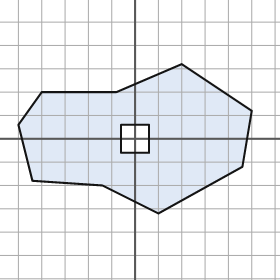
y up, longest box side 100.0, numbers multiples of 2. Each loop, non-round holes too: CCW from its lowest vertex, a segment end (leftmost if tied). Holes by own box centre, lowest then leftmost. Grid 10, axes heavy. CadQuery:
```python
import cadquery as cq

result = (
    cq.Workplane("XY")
    .moveTo(10.0, -32.0)
    .lineTo(46.0, -12.0)
    .lineTo(50.0, 12.0)
    .lineTo(20.0, 32.0)
    .lineTo(-8.0, 20.0)
    .lineTo(-40.0, 20.0)
    .lineTo(-50.0, 6.0)
    .lineTo(-44.0, -18.0)
    .lineTo(-14.0, -20.0)
    .close()
    .moveTo(-6.0, -6.0)
    .lineTo(6.0, -6.0)
    .lineTo(6.0, 6.0)
    .lineTo(-6.0, 6.0)
    .close()
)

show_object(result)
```